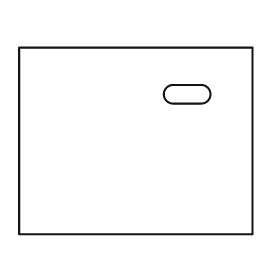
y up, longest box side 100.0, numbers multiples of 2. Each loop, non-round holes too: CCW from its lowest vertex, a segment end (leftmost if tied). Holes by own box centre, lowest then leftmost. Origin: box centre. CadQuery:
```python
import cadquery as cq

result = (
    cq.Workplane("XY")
    .moveTo(-50.0, -40.0)
    .lineTo(50.0, -40.0)
    .lineTo(50.0, 40.0)
    .lineTo(-50.0, 40.0)
    .close()
    .moveTo(16.0, 16.0)
    .lineTo(28.0, 16.0)
    .threePointArc((32.0, 20.0), (28.0, 24.0))
    .lineTo(16.0, 24.0)
    .threePointArc((12.0, 20.0), (16.0, 16.0))
    .close()
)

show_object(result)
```